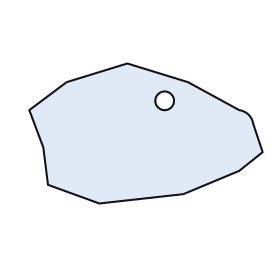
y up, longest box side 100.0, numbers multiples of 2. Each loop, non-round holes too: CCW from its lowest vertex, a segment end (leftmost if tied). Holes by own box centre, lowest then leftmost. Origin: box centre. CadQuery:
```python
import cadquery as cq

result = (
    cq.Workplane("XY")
    .moveTo(-20.0, -30.0)
    .lineTo(16.0, -26.0)
    .lineTo(40.0, -16.0)
    .lineTo(50.0, -8.0)
    .lineTo(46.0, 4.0)
    .threePointArc((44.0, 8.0), (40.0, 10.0))
    .lineTo(18.0, 22.0)
    .lineTo(-8.0, 30.0)
    .lineTo(-34.0, 22.0)
    .lineTo(-50.0, 10.0)
    .lineTo(-44.0, -6.0)
    .lineTo(-42.0, -22.0)
    .close()
    .moveTo(8.0, 14.0)
    .circle(4.0)
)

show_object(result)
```